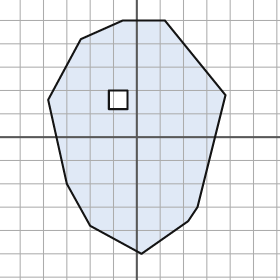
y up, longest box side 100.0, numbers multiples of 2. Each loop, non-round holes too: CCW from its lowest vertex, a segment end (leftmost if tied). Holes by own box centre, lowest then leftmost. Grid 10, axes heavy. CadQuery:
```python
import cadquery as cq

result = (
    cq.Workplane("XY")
    .moveTo(2.0, -50.0)
    .lineTo(22.0, -36.0)
    .lineTo(26.0, -30.0)
    .lineTo(38.0, 18.0)
    .lineTo(12.0, 50.0)
    .lineTo(-6.0, 50.0)
    .lineTo(-24.0, 42.0)
    .lineTo(-38.0, 16.0)
    .lineTo(-30.0, -20.0)
    .lineTo(-20.0, -38.0)
    .close()
    .moveTo(-12.0, 12.0)
    .lineTo(-4.0, 12.0)
    .lineTo(-4.0, 20.0)
    .lineTo(-12.0, 20.0)
    .close()
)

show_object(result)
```